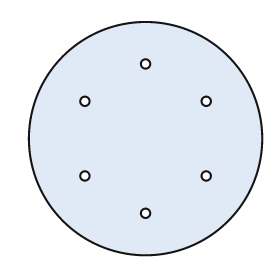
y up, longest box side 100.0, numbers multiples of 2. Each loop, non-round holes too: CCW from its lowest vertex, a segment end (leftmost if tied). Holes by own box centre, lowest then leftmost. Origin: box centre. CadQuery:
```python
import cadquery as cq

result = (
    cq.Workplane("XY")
    .moveTo(0.0, 0.0)
    .circle(50.0)
    .moveTo(0.0, -32.0)
    .circle(2.0)
    .moveTo(-26.0, -16.0)
    .circle(2.0)
    .moveTo(26.0, -16.0)
    .circle(2.0)
    .moveTo(-26.0, 16.0)
    .circle(2.0)
    .moveTo(26.0, 16.0)
    .circle(2.0)
    .moveTo(0.0, 32.0)
    .circle(2.0)
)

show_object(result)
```